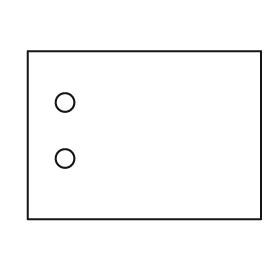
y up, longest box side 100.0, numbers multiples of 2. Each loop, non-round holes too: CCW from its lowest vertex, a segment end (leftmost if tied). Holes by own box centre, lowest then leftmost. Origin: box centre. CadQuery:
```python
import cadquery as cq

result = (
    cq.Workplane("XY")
    .moveTo(-50.0, -36.0)
    .lineTo(50.0, -36.0)
    .lineTo(50.0, 36.0)
    .lineTo(-50.0, 36.0)
    .close()
    .moveTo(-34.0, -10.0)
    .circle(4.0)
    .moveTo(-34.0, 14.0)
    .circle(4.0)
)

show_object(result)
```